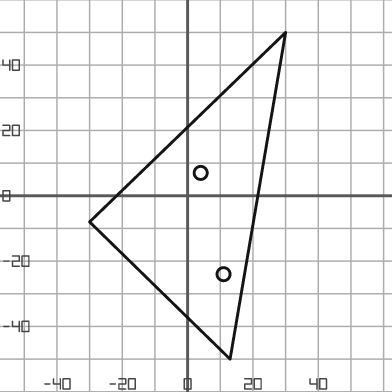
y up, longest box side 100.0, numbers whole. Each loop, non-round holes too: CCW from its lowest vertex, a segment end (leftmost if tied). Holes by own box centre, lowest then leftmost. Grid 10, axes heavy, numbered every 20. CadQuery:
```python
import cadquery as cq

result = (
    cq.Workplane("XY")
    .moveTo(13.0, -50.0)
    .lineTo(30.0, 50.0)
    .lineTo(-30.0, -8.0)
    .close()
    .moveTo(11.0, -24.0)
    .circle(2.0)
    .moveTo(4.0, 7.0)
    .circle(2.0)
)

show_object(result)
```